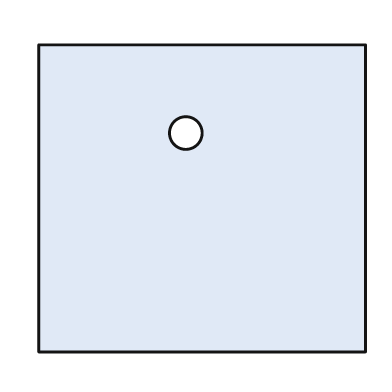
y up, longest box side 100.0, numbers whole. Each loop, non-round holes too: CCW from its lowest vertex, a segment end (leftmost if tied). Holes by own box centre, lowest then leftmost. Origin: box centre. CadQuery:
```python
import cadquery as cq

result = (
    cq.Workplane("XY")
    .moveTo(-50.0, -47.0)
    .lineTo(50.0, -47.0)
    .lineTo(50.0, 47.0)
    .lineTo(-50.0, 47.0)
    .close()
    .moveTo(-5.0, 20.0)
    .circle(5.0)
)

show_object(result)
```